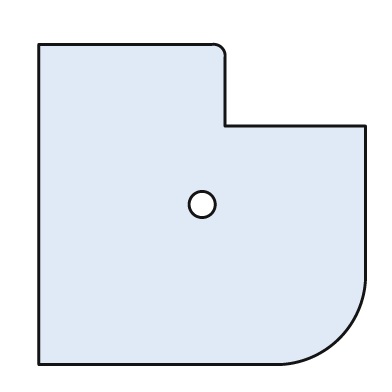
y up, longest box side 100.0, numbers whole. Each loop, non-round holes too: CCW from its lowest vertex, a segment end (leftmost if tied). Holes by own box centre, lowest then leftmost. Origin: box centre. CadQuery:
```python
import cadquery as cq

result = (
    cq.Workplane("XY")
    .moveTo(-50.0, -49.0)
    .lineTo(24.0, -49.0)
    .threePointArc((42.0, -41.0), (50.0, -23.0))
    .lineTo(50.0, 24.0)
    .lineTo(7.0, 24.0)
    .lineTo(7.0, 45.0)
    .threePointArc((6.0, 48.0), (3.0, 49.0))
    .lineTo(-50.0, 49.0)
    .close()
    .moveTo(0.0, 0.0)
    .circle(4.0)
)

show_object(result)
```